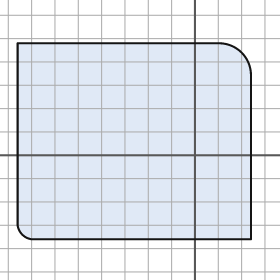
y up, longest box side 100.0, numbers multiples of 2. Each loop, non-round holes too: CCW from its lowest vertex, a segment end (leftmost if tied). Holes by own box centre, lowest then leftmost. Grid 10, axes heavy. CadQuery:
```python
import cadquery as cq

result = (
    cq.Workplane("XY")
    .moveTo(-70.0, -36.0)
    .lineTo(24.0, -36.0)
    .lineTo(24.0, 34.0)
    .threePointArc((20.0, 44.0), (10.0, 48.0))
    .lineTo(-76.0, 48.0)
    .lineTo(-76.0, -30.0)
    .threePointArc((-74.0, -34.0), (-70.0, -36.0))
    .close()
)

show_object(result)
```